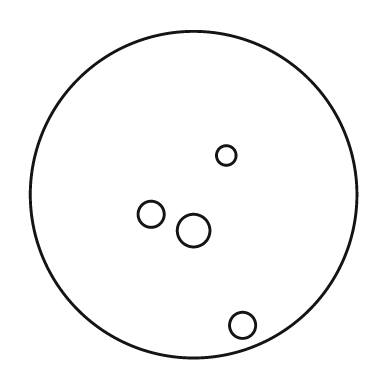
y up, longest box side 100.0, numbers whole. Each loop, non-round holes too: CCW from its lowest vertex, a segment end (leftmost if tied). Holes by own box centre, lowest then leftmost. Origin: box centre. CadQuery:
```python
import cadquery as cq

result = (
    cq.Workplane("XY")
    .moveTo(0.0, 0.0)
    .circle(50.0)
    .moveTo(15.0, -40.0)
    .circle(4.0)
    .moveTo(0.0, -11.0)
    .circle(5.0)
    .moveTo(-13.0, -6.0)
    .circle(4.0)
    .moveTo(10.0, 12.0)
    .circle(3.0)
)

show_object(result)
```